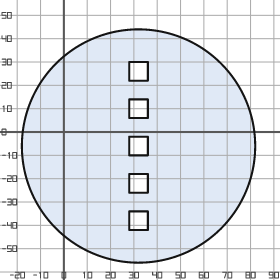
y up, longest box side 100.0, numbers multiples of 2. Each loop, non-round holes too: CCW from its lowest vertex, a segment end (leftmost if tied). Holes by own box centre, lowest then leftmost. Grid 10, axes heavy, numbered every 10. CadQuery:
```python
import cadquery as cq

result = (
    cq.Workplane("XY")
    .moveTo(32.0, -6.0)
    .circle(50.0)
    .moveTo(28.0, -42.0)
    .lineTo(36.0, -42.0)
    .lineTo(36.0, -34.0)
    .lineTo(28.0, -34.0)
    .close()
    .moveTo(28.0, -26.0)
    .lineTo(36.0, -26.0)
    .lineTo(36.0, -18.0)
    .lineTo(28.0, -18.0)
    .close()
    .moveTo(28.0, -10.0)
    .lineTo(36.0, -10.0)
    .lineTo(36.0, -2.0)
    .lineTo(28.0, -2.0)
    .close()
    .moveTo(28.0, 6.0)
    .lineTo(36.0, 6.0)
    .lineTo(36.0, 14.0)
    .lineTo(28.0, 14.0)
    .close()
    .moveTo(28.0, 22.0)
    .lineTo(36.0, 22.0)
    .lineTo(36.0, 30.0)
    .lineTo(28.0, 30.0)
    .close()
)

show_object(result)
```